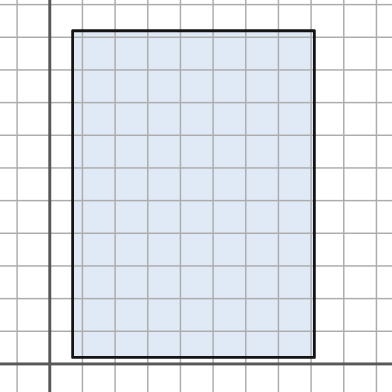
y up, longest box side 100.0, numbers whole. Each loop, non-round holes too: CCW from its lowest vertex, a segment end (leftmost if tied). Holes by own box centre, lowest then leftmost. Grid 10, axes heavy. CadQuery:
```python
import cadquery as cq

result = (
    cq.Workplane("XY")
    .moveTo(7.0, 2.0)
    .lineTo(81.0, 2.0)
    .lineTo(81.0, 102.0)
    .lineTo(7.0, 102.0)
    .close()
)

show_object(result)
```